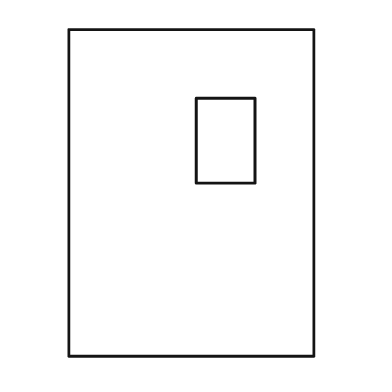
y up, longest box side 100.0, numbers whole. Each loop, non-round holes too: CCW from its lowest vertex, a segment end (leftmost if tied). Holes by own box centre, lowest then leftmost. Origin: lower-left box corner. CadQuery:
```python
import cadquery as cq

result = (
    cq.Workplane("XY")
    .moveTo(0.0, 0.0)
    .lineTo(75.0, 0.0)
    .lineTo(75.0, 100.0)
    .lineTo(0.0, 100.0)
    .close()
    .moveTo(39.0, 53.0)
    .lineTo(57.0, 53.0)
    .lineTo(57.0, 79.0)
    .lineTo(39.0, 79.0)
    .close()
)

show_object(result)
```